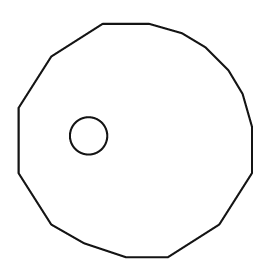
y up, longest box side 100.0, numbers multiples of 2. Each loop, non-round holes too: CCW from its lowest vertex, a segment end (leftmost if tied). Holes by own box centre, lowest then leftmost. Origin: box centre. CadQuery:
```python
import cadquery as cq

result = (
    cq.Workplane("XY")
    .moveTo(-4.0, -50.0)
    .lineTo(14.0, -50.0)
    .lineTo(36.0, -36.0)
    .lineTo(50.0, -14.0)
    .lineTo(50.0, 6.0)
    .lineTo(46.0, 20.0)
    .lineTo(40.0, 30.0)
    .lineTo(30.0, 40.0)
    .lineTo(20.0, 46.0)
    .lineTo(6.0, 50.0)
    .lineTo(-14.0, 50.0)
    .lineTo(-36.0, 36.0)
    .lineTo(-50.0, 14.0)
    .lineTo(-50.0, -14.0)
    .lineTo(-36.0, -36.0)
    .lineTo(-22.0, -44.0)
    .close()
    .moveTo(-20.0, 2.0)
    .circle(8.0)
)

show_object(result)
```